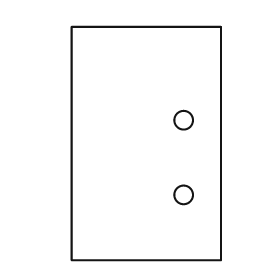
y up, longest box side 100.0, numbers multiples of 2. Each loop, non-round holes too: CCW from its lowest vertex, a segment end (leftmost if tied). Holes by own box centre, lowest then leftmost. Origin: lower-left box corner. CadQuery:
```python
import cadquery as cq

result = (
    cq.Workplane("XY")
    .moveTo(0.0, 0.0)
    .lineTo(64.0, 0.0)
    .lineTo(64.0, 100.0)
    .lineTo(0.0, 100.0)
    .close()
    .moveTo(48.0, 28.0)
    .circle(4.0)
    .moveTo(48.0, 60.0)
    .circle(4.0)
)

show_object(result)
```